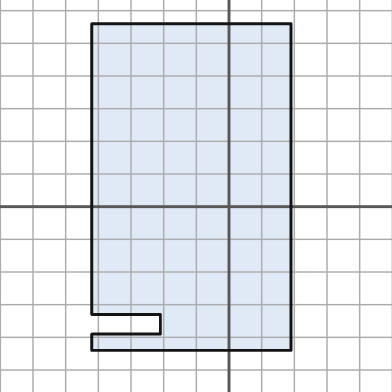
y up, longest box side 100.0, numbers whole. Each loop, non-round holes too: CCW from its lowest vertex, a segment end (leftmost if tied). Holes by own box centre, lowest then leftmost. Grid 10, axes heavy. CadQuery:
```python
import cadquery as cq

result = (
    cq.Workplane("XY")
    .moveTo(-42.0, -44.0)
    .lineTo(19.0, -44.0)
    .lineTo(19.0, 56.0)
    .lineTo(-42.0, 56.0)
    .lineTo(-42.0, -33.0)
    .lineTo(-21.0, -33.0)
    .lineTo(-21.0, -39.0)
    .lineTo(-42.0, -39.0)
    .close()
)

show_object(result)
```